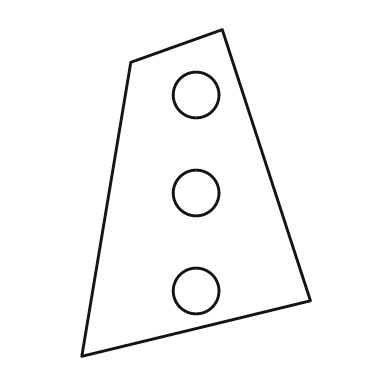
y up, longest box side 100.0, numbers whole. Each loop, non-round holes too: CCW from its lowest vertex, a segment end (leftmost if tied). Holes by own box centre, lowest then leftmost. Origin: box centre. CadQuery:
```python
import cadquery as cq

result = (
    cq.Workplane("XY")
    .moveTo(-35.0, -50.0)
    .lineTo(35.0, -33.0)
    .lineTo(8.0, 50.0)
    .lineTo(-20.0, 40.0)
    .close()
    .moveTo(0.0, -30.0)
    .circle(7.0)
    .moveTo(0.0, 0.0)
    .circle(7.0)
    .moveTo(0.0, 30.0)
    .circle(7.0)
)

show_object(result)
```